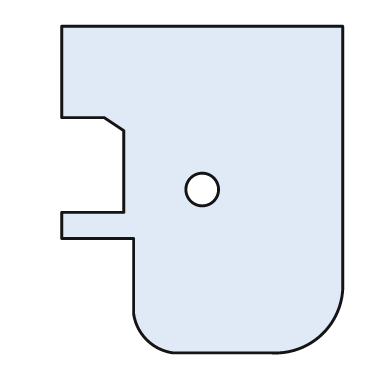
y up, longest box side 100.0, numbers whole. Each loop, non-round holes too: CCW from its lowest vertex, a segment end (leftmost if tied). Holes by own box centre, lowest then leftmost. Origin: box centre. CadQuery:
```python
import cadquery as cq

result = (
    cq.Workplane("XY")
    .moveTo(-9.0, -50.0)
    .lineTo(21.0, -50.0)
    .threePointArc((37.0, -44.0), (43.0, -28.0))
    .lineTo(43.0, 50.0)
    .lineTo(-43.0, 50.0)
    .lineTo(-43.0, 22.0)
    .lineTo(-30.0, 22.0)
    .lineTo(-24.0, 18.0)
    .lineTo(-24.0, -7.0)
    .lineTo(-43.0, -7.0)
    .lineTo(-43.0, -15.0)
    .lineTo(-21.0, -15.0)
    .lineTo(-21.0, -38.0)
    .threePointArc((-17.0, -46.0), (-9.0, -50.0))
    .close()
    .moveTo(0.0, 0.0)
    .circle(5.0)
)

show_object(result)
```